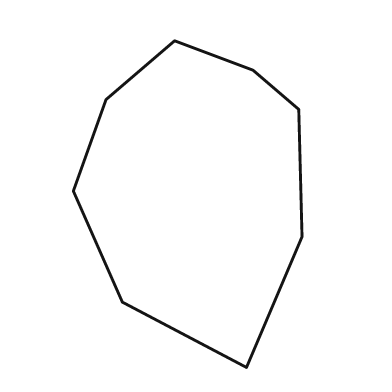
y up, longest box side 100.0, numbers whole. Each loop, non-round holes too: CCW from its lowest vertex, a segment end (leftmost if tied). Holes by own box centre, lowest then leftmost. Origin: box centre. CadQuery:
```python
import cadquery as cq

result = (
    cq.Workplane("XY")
    .moveTo(18.0, -50.0)
    .lineTo(35.0, -10.0)
    .lineTo(34.0, 29.0)
    .lineTo(20.0, 41.0)
    .lineTo(-4.0, 50.0)
    .lineTo(-25.0, 32.0)
    .lineTo(-35.0, 4.0)
    .lineTo(-20.0, -30.0)
    .close()
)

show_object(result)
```